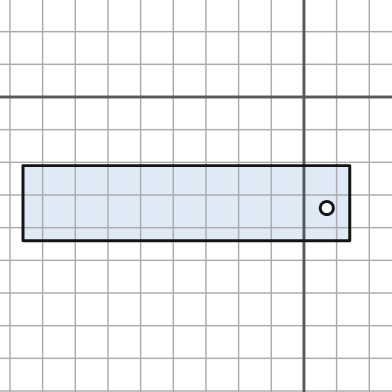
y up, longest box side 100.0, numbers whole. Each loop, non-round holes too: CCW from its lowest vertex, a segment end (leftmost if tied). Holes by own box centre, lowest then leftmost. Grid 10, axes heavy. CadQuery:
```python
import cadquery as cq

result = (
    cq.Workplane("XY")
    .moveTo(-86.0, -44.0)
    .lineTo(14.0, -44.0)
    .lineTo(14.0, -21.0)
    .lineTo(-86.0, -21.0)
    .close()
    .moveTo(7.0, -34.0)
    .circle(2.0)
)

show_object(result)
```